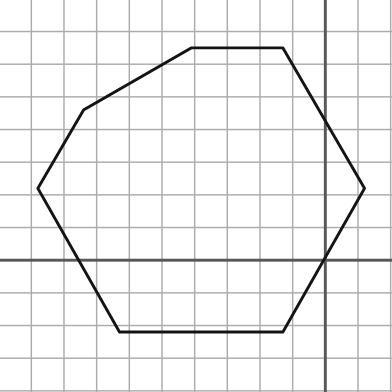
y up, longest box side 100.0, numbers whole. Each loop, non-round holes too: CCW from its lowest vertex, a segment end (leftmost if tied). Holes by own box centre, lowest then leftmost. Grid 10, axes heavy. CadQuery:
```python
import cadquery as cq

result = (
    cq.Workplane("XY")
    .moveTo(-63.0, -22.0)
    .lineTo(-13.0, -22.0)
    .lineTo(12.0, 22.0)
    .lineTo(-13.0, 65.0)
    .lineTo(-41.0, 65.0)
    .lineTo(-74.0, 46.0)
    .lineTo(-88.0, 22.0)
    .close()
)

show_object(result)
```